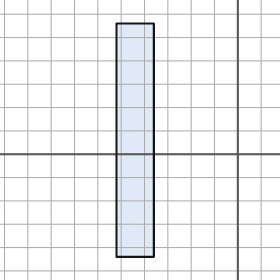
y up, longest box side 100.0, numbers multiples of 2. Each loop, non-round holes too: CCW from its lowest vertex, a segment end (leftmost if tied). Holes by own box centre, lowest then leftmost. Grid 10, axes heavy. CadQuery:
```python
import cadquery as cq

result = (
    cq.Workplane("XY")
    .moveTo(-52.0, -44.0)
    .lineTo(-36.0, -44.0)
    .lineTo(-36.0, 56.0)
    .lineTo(-52.0, 56.0)
    .close()
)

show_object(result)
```